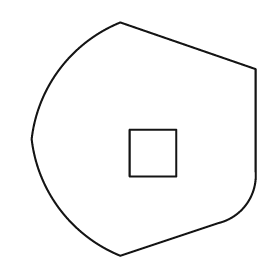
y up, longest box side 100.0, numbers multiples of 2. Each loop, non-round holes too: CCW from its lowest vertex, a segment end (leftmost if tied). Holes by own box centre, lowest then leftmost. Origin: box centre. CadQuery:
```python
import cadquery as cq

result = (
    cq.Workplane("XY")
    .moveTo(-10.0, -50.0)
    .lineTo(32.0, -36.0)
    .threePointArc((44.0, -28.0), (48.0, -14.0))
    .lineTo(48.0, 30.0)
    .lineTo(-10.0, 50.0)
    .threePointArc((-36.0, 30.0), (-48.0, 0.0))
    .threePointArc((-36.0, -30.0), (-10.0, -50.0))
    .close()
    .moveTo(-6.0, -16.0)
    .lineTo(14.0, -16.0)
    .lineTo(14.0, 4.0)
    .lineTo(-6.0, 4.0)
    .close()
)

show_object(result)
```